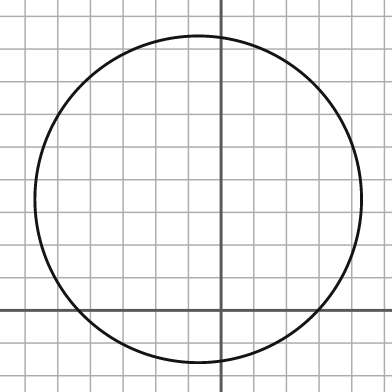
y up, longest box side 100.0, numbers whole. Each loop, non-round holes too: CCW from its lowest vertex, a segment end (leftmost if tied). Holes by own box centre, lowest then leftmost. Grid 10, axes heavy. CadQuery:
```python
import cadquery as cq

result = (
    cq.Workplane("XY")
    .moveTo(-7.0, 34.0)
    .circle(50.0)
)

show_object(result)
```